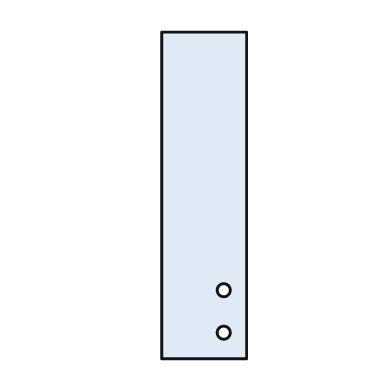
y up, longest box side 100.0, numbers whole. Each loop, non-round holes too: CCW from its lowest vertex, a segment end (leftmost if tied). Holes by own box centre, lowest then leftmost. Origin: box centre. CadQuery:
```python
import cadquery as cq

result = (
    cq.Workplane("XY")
    .moveTo(-13.0, -50.0)
    .lineTo(13.0, -50.0)
    .lineTo(13.0, 50.0)
    .lineTo(-13.0, 50.0)
    .close()
    .moveTo(6.0, -42.0)
    .circle(2.0)
    .moveTo(6.0, -29.0)
    .circle(2.0)
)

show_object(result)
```